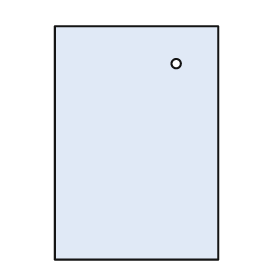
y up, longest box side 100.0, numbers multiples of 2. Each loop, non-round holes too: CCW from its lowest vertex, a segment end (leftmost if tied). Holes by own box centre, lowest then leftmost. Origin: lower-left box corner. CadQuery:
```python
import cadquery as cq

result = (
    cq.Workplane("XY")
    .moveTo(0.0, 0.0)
    .lineTo(70.0, 0.0)
    .lineTo(70.0, 100.0)
    .lineTo(0.0, 100.0)
    .close()
    .moveTo(52.0, 84.0)
    .circle(2.0)
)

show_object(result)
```